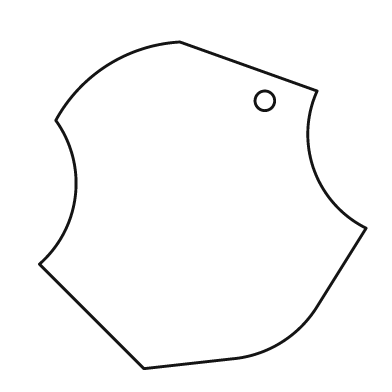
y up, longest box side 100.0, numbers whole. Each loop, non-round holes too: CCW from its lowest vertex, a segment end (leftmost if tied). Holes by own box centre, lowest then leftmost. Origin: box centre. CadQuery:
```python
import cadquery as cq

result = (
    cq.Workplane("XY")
    .moveTo(-18.0, -50.0)
    .lineTo(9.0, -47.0)
    .threePointArc((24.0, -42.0), (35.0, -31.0))
    .lineTo(50.0, -7.0)
    .threePointArc((34.0, 11.0), (35.0, 35.0))
    .lineTo(-7.0, 50.0)
    .threePointArc((-29.0, 43.0), (-45.0, 26.0))
    .threePointArc((-39.0, 3.0), (-50.0, -18.0))
    .close()
    .moveTo(19.0, 32.0)
    .circle(3.0)
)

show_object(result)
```